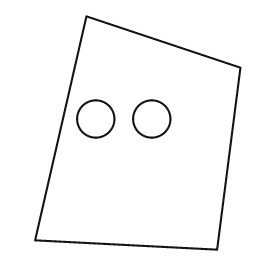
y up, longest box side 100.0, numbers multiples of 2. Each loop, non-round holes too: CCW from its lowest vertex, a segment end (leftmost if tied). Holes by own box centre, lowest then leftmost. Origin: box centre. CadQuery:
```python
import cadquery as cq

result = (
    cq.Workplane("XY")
    .moveTo(34.0, -50.0)
    .lineTo(44.0, 28.0)
    .lineTo(-22.0, 50.0)
    .lineTo(-44.0, -46.0)
    .close()
    .moveTo(-18.0, 6.0)
    .circle(8.0)
    .moveTo(6.0, 6.0)
    .circle(8.0)
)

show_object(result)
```